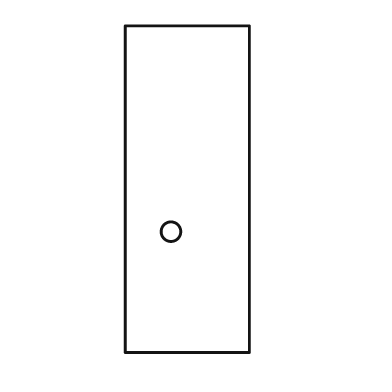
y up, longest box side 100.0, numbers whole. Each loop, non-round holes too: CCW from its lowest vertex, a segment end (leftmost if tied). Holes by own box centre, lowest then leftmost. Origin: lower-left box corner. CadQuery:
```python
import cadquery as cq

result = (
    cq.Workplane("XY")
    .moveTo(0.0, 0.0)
    .lineTo(38.0, 0.0)
    .lineTo(38.0, 100.0)
    .lineTo(0.0, 100.0)
    .close()
    .moveTo(14.0, 37.0)
    .circle(3.0)
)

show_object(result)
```